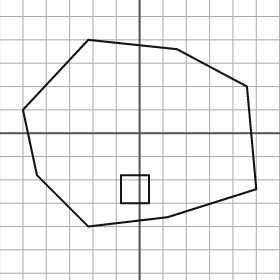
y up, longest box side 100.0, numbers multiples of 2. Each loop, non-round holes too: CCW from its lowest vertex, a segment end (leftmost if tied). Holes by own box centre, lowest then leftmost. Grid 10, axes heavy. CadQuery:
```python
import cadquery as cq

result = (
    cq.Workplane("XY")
    .moveTo(-22.0, -40.0)
    .lineTo(12.0, -36.0)
    .lineTo(50.0, -24.0)
    .lineTo(46.0, 20.0)
    .lineTo(16.0, 36.0)
    .lineTo(-22.0, 40.0)
    .lineTo(-50.0, 10.0)
    .lineTo(-44.0, -18.0)
    .close()
    .moveTo(-8.0, -30.0)
    .lineTo(4.0, -30.0)
    .lineTo(4.0, -18.0)
    .lineTo(-8.0, -18.0)
    .close()
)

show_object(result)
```